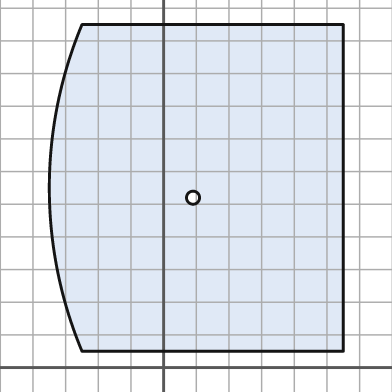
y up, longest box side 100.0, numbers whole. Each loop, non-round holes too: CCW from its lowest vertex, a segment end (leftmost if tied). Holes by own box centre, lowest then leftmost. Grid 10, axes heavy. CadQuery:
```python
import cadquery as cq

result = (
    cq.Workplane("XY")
    .moveTo(-25.0, 5.0)
    .lineTo(55.0, 5.0)
    .lineTo(55.0, 105.0)
    .lineTo(-25.0, 105.0)
    .threePointArc((-35.0, 55.0), (-25.0, 5.0))
    .close()
    .moveTo(9.0, 52.0)
    .circle(2.0)
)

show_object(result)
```